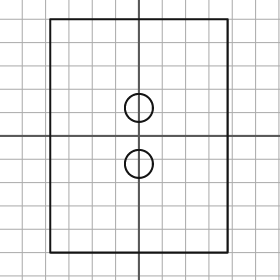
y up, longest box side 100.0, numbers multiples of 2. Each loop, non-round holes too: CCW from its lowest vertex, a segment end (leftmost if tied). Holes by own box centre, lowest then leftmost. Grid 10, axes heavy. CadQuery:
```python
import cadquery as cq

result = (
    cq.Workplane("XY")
    .moveTo(-38.0, -50.0)
    .lineTo(38.0, -50.0)
    .lineTo(38.0, 50.0)
    .lineTo(-38.0, 50.0)
    .close()
    .moveTo(0.0, -12.0)
    .circle(6.0)
    .moveTo(0.0, 12.0)
    .circle(6.0)
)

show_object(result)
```